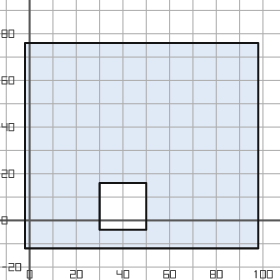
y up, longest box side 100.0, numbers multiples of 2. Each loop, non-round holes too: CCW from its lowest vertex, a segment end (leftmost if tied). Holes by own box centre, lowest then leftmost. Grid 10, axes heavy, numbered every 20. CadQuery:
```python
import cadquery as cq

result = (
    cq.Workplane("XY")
    .moveTo(-2.0, -12.0)
    .lineTo(98.0, -12.0)
    .lineTo(98.0, 76.0)
    .lineTo(-2.0, 76.0)
    .close()
    .moveTo(30.0, -4.0)
    .lineTo(50.0, -4.0)
    .lineTo(50.0, 16.0)
    .lineTo(30.0, 16.0)
    .close()
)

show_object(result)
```